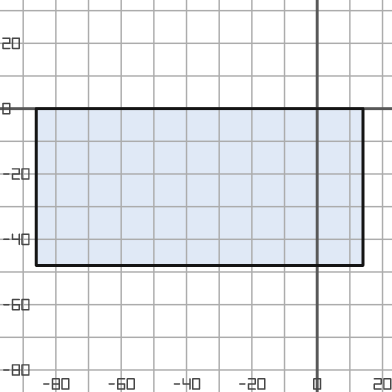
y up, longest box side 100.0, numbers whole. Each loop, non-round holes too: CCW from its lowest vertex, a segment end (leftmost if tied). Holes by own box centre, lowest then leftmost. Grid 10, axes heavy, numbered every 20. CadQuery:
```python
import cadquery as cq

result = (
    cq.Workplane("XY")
    .moveTo(-86.0, -48.0)
    .lineTo(14.0, -48.0)
    .lineTo(14.0, 0.0)
    .lineTo(-86.0, 0.0)
    .close()
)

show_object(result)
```